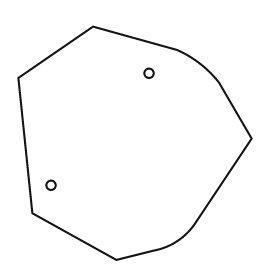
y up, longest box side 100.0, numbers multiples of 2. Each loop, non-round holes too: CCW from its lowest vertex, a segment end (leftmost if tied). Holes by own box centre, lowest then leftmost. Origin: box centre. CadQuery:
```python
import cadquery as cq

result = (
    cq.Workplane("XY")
    .moveTo(-8.0, -50.0)
    .lineTo(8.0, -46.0)
    .threePointArc((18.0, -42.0), (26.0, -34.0))
    .lineTo(50.0, 2.0)
    .lineTo(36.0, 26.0)
    .threePointArc((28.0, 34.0), (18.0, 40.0))
    .lineTo(-18.0, 50.0)
    .lineTo(-50.0, 28.0)
    .lineTo(-44.0, -30.0)
    .close()
    .moveTo(-36.0, -18.0)
    .circle(2.0)
    .moveTo(6.0, 30.0)
    .circle(2.0)
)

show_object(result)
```